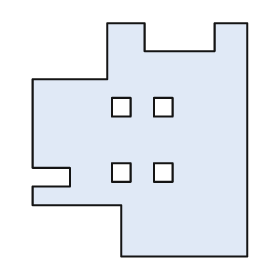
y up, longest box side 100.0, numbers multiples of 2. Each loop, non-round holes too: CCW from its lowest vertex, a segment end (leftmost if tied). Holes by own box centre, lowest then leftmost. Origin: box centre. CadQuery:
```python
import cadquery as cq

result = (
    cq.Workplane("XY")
    .moveTo(-8.0, -50.0)
    .lineTo(46.0, -50.0)
    .lineTo(46.0, 50.0)
    .lineTo(32.0, 50.0)
    .lineTo(32.0, 38.0)
    .lineTo(2.0, 38.0)
    .lineTo(2.0, 50.0)
    .lineTo(-14.0, 50.0)
    .lineTo(-14.0, 26.0)
    .lineTo(-46.0, 26.0)
    .lineTo(-46.0, -12.0)
    .lineTo(-30.0, -12.0)
    .lineTo(-30.0, -20.0)
    .lineTo(-46.0, -20.0)
    .lineTo(-46.0, -28.0)
    .lineTo(-8.0, -28.0)
    .close()
    .moveTo(-12.0, -18.0)
    .lineTo(-4.0, -18.0)
    .lineTo(-4.0, -10.0)
    .lineTo(-12.0, -10.0)
    .close()
    .moveTo(6.0, -18.0)
    .lineTo(14.0, -18.0)
    .lineTo(14.0, -10.0)
    .lineTo(6.0, -10.0)
    .close()
    .moveTo(-12.0, 10.0)
    .lineTo(-4.0, 10.0)
    .lineTo(-4.0, 18.0)
    .lineTo(-12.0, 18.0)
    .close()
    .moveTo(6.0, 10.0)
    .lineTo(14.0, 10.0)
    .lineTo(14.0, 18.0)
    .lineTo(6.0, 18.0)
    .close()
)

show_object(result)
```